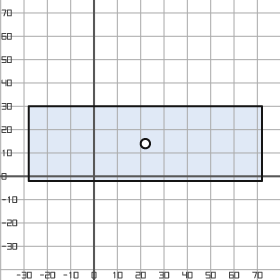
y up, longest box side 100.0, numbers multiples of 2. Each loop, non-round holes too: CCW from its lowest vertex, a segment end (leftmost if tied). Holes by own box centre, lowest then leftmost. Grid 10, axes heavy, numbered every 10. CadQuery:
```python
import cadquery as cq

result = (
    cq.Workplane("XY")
    .moveTo(-28.0, -2.0)
    .lineTo(72.0, -2.0)
    .lineTo(72.0, 30.0)
    .lineTo(-28.0, 30.0)
    .close()
    .moveTo(22.0, 14.0)
    .circle(2.0)
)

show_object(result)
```